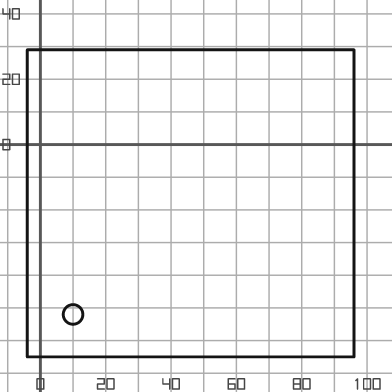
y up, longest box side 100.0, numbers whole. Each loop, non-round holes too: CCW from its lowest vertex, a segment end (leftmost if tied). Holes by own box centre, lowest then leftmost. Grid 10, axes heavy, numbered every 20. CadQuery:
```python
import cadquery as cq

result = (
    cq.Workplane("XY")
    .moveTo(-4.0, -65.0)
    .lineTo(96.0, -65.0)
    .lineTo(96.0, 29.0)
    .lineTo(-4.0, 29.0)
    .close()
    .moveTo(10.0, -52.0)
    .circle(3.0)
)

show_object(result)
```